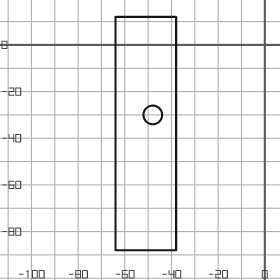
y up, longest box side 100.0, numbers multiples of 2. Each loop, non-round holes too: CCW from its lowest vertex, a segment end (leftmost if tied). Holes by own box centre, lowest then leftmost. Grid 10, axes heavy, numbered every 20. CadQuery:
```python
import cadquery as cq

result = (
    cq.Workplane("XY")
    .moveTo(-64.0, -88.0)
    .lineTo(-38.0, -88.0)
    .lineTo(-38.0, 12.0)
    .lineTo(-64.0, 12.0)
    .close()
    .moveTo(-48.0, -30.0)
    .circle(4.0)
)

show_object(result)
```